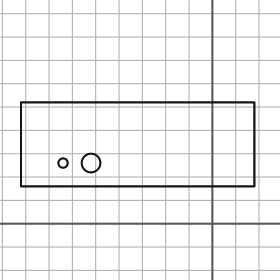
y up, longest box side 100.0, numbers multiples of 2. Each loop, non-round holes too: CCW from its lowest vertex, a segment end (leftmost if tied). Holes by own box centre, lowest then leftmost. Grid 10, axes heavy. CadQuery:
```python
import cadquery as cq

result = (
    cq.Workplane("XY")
    .moveTo(-82.0, 16.0)
    .lineTo(18.0, 16.0)
    .lineTo(18.0, 52.0)
    .lineTo(-82.0, 52.0)
    .close()
    .moveTo(-64.0, 26.0)
    .circle(2.0)
    .moveTo(-52.0, 26.0)
    .circle(4.0)
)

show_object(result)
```